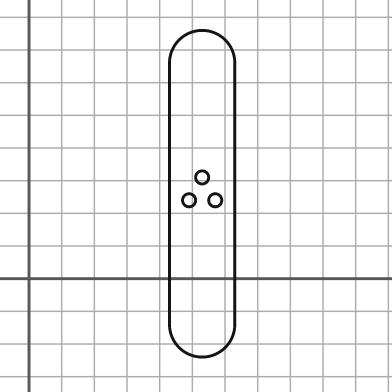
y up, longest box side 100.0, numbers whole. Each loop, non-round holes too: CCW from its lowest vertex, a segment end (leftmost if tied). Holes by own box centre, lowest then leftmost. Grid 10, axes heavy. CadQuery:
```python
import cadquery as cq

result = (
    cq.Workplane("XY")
    .moveTo(43.0, -14.0)
    .threePointArc((53.0, -24.0), (63.0, -14.0))
    .lineTo(63.0, 66.0)
    .threePointArc((53.0, 76.0), (43.0, 66.0))
    .close()
    .moveTo(49.0, 24.0)
    .circle(2.0)
    .moveTo(57.0, 24.0)
    .circle(2.0)
    .moveTo(53.0, 31.0)
    .circle(2.0)
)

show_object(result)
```